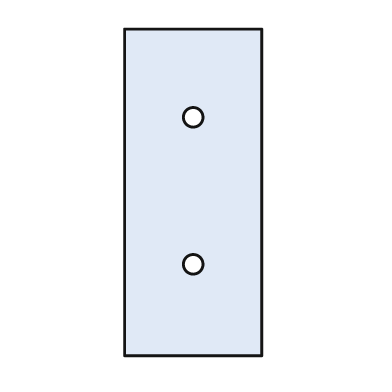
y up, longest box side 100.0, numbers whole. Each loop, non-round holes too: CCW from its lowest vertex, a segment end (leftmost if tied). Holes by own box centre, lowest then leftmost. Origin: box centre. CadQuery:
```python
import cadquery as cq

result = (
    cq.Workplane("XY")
    .moveTo(-21.0, -50.0)
    .lineTo(21.0, -50.0)
    .lineTo(21.0, 50.0)
    .lineTo(-21.0, 50.0)
    .close()
    .moveTo(0.0, -22.0)
    .circle(3.0)
    .moveTo(0.0, 23.0)
    .circle(3.0)
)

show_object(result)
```